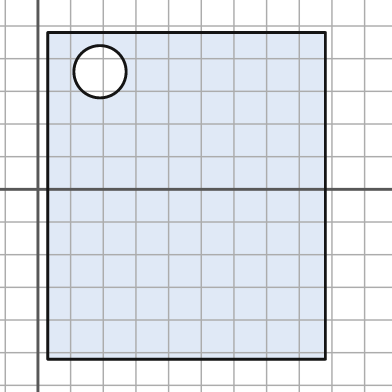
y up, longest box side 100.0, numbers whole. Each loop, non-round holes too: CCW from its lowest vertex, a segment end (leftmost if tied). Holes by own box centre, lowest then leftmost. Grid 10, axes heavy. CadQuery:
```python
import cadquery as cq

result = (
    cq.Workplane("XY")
    .moveTo(3.0, -52.0)
    .lineTo(88.0, -52.0)
    .lineTo(88.0, 48.0)
    .lineTo(3.0, 48.0)
    .close()
    .moveTo(19.0, 36.0)
    .circle(8.0)
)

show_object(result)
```